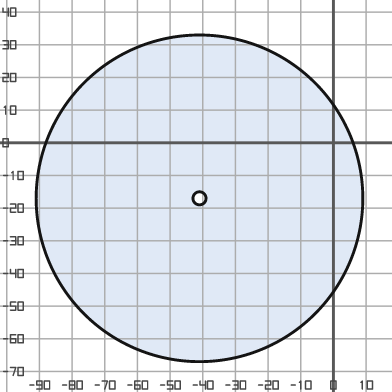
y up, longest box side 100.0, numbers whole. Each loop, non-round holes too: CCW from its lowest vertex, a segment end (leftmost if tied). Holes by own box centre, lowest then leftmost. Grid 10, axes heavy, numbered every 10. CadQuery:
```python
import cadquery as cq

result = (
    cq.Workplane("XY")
    .moveTo(-41.0, -17.0)
    .circle(50.0)
    .moveTo(-41.0, -17.0)
    .circle(2.0)
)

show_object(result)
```